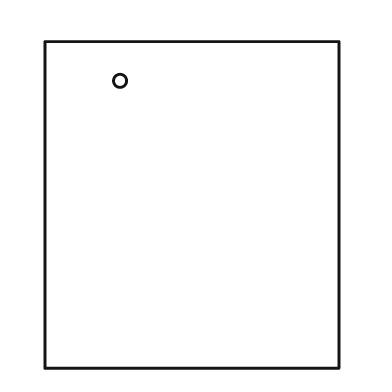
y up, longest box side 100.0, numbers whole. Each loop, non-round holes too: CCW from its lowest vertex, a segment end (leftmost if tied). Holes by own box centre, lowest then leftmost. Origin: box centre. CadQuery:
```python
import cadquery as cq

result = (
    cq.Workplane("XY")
    .moveTo(-45.0, -50.0)
    .lineTo(45.0, -50.0)
    .lineTo(45.0, 50.0)
    .lineTo(-45.0, 50.0)
    .close()
    .moveTo(-22.0, 38.0)
    .circle(2.0)
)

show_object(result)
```